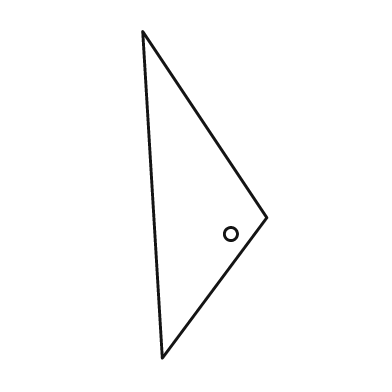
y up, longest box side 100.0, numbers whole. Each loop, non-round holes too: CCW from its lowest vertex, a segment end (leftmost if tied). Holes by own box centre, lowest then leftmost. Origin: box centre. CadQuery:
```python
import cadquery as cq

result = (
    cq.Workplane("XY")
    .moveTo(-13.0, -50.0)
    .lineTo(19.0, -7.0)
    .lineTo(-19.0, 50.0)
    .close()
    .moveTo(8.0, -12.0)
    .circle(2.0)
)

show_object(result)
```